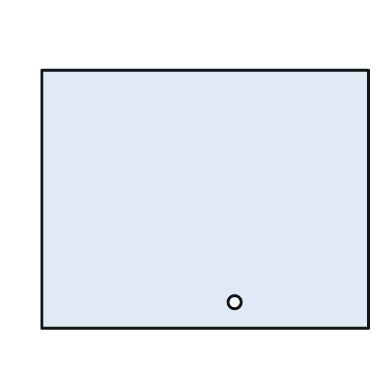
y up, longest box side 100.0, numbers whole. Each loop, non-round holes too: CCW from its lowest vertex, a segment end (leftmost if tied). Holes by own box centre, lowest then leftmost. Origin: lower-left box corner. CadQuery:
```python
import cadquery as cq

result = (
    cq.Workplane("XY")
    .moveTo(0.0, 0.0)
    .lineTo(100.0, 0.0)
    .lineTo(100.0, 79.0)
    .lineTo(0.0, 79.0)
    .close()
    .moveTo(59.0, 8.0)
    .circle(2.0)
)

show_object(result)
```